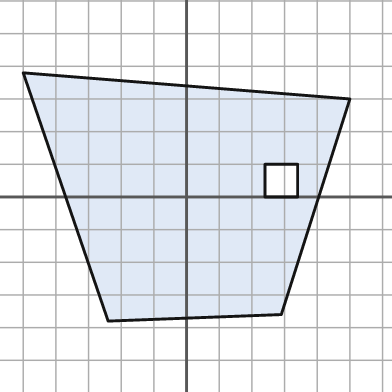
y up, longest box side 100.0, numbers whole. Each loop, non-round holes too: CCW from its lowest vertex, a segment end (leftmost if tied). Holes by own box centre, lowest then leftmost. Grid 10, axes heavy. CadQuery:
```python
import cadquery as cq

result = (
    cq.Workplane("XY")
    .moveTo(-24.0, -38.0)
    .lineTo(29.0, -36.0)
    .lineTo(50.0, 30.0)
    .lineTo(-50.0, 38.0)
    .close()
    .moveTo(24.0, 0.0)
    .lineTo(34.0, 0.0)
    .lineTo(34.0, 10.0)
    .lineTo(24.0, 10.0)
    .close()
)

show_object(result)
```